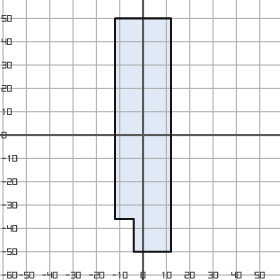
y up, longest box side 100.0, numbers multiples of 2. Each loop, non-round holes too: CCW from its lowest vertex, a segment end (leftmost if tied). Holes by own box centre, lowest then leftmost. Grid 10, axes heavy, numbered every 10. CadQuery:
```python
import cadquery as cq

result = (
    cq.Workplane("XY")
    .moveTo(-4.0, -50.0)
    .lineTo(12.0, -50.0)
    .lineTo(12.0, 50.0)
    .lineTo(-12.0, 50.0)
    .lineTo(-12.0, -36.0)
    .lineTo(-4.0, -36.0)
    .close()
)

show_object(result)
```